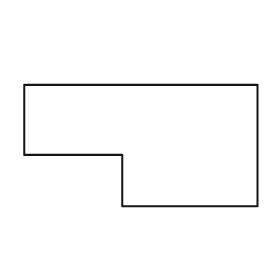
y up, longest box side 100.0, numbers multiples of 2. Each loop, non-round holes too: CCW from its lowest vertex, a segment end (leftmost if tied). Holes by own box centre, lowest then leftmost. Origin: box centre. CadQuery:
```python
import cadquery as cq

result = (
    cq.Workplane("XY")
    .moveTo(-8.0, -26.0)
    .lineTo(50.0, -26.0)
    .lineTo(50.0, 26.0)
    .lineTo(-50.0, 26.0)
    .lineTo(-50.0, -4.0)
    .lineTo(-8.0, -4.0)
    .close()
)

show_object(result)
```